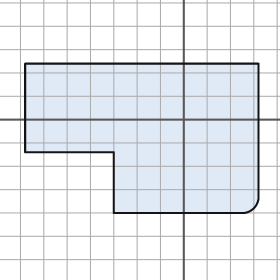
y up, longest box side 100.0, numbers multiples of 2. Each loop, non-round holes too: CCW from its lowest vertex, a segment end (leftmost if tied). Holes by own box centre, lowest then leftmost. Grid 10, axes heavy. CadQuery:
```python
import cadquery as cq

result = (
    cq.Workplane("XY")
    .moveTo(-30.0, -40.0)
    .lineTo(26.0, -40.0)
    .threePointArc((30.0, -38.0), (32.0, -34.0))
    .lineTo(32.0, 24.0)
    .lineTo(-68.0, 24.0)
    .lineTo(-68.0, -14.0)
    .lineTo(-30.0, -14.0)
    .close()
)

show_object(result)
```